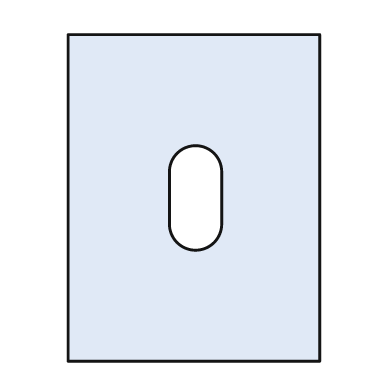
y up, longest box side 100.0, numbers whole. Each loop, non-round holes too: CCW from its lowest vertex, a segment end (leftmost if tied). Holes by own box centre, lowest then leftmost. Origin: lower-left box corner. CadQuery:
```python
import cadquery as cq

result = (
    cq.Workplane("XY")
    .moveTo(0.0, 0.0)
    .lineTo(77.0, 0.0)
    .lineTo(77.0, 100.0)
    .lineTo(0.0, 100.0)
    .close()
    .moveTo(31.0, 42.0)
    .threePointArc((39.0, 34.0), (47.0, 42.0))
    .lineTo(47.0, 58.0)
    .threePointArc((39.0, 66.0), (31.0, 58.0))
    .close()
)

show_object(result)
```